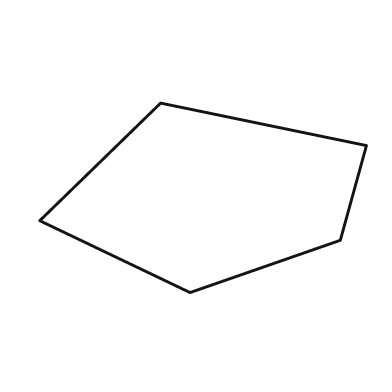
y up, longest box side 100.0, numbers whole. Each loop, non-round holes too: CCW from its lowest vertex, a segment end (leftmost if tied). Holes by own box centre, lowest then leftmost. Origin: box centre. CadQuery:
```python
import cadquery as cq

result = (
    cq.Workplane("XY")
    .moveTo(-4.0, -29.0)
    .lineTo(42.0, -13.0)
    .lineTo(50.0, 16.0)
    .lineTo(-13.0, 29.0)
    .lineTo(-50.0, -7.0)
    .close()
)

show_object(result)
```